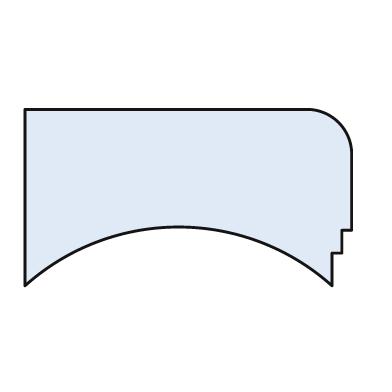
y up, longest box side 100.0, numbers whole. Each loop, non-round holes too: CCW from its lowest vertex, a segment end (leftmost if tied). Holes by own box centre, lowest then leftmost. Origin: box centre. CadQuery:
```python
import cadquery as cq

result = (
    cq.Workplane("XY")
    .moveTo(-50.0, -27.0)
    .threePointArc((-3.0, -9.0), (44.0, -27.0))
    .lineTo(44.0, -17.0)
    .lineTo(47.0, -17.0)
    .lineTo(47.0, -10.0)
    .lineTo(50.0, -10.0)
    .lineTo(50.0, 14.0)
    .threePointArc((46.0, 23.0), (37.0, 27.0))
    .lineTo(-50.0, 27.0)
    .close()
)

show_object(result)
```